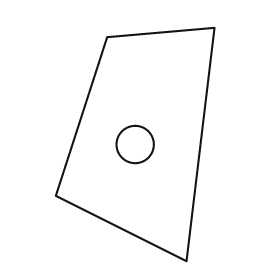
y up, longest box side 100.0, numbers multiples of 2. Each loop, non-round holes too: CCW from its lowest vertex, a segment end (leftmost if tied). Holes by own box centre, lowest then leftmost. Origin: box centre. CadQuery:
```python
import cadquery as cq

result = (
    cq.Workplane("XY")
    .moveTo(22.0, -50.0)
    .lineTo(34.0, 50.0)
    .lineTo(-12.0, 46.0)
    .lineTo(-34.0, -22.0)
    .close()
    .moveTo(0.0, 0.0)
    .circle(8.0)
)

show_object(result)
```